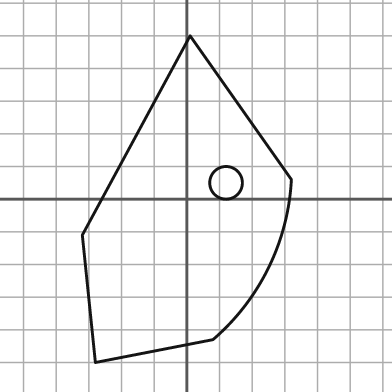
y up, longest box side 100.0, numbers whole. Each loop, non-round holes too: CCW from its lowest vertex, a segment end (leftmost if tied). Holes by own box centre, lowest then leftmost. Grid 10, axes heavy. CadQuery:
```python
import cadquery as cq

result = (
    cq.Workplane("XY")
    .moveTo(-28.0, -50.0)
    .lineTo(8.0, -43.0)
    .threePointArc((25.0, -21.0), (32.0, 6.0))
    .lineTo(1.0, 50.0)
    .lineTo(-32.0, -11.0)
    .close()
    .moveTo(12.0, 5.0)
    .circle(5.0)
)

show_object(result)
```